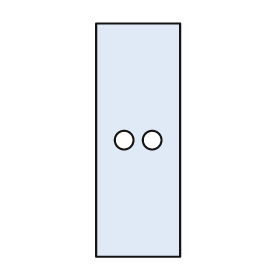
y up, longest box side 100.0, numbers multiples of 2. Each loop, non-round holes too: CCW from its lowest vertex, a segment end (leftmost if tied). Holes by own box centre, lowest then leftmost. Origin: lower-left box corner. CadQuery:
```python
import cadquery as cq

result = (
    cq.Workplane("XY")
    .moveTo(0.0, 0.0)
    .lineTo(36.0, 0.0)
    .lineTo(36.0, 100.0)
    .lineTo(0.0, 100.0)
    .close()
    .moveTo(12.0, 50.0)
    .circle(4.0)
    .moveTo(24.0, 50.0)
    .circle(4.0)
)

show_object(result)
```